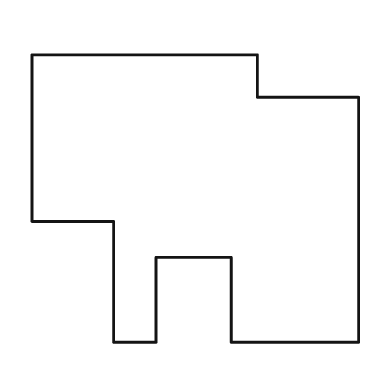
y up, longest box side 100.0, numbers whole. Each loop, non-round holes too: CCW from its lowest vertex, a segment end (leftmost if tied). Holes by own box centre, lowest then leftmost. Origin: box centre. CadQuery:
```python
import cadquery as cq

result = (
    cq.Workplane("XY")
    .moveTo(-25.0, -44.0)
    .lineTo(-12.0, -44.0)
    .lineTo(-12.0, -18.0)
    .lineTo(11.0, -18.0)
    .lineTo(11.0, -44.0)
    .lineTo(50.0, -44.0)
    .lineTo(50.0, 31.0)
    .lineTo(19.0, 31.0)
    .lineTo(19.0, 44.0)
    .lineTo(-50.0, 44.0)
    .lineTo(-50.0, -7.0)
    .lineTo(-25.0, -7.0)
    .close()
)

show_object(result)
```